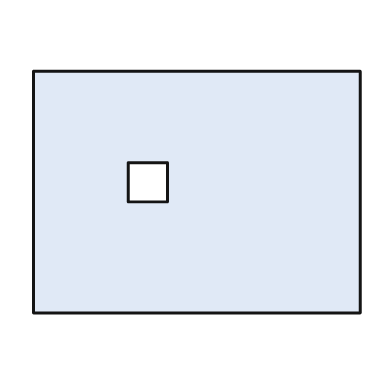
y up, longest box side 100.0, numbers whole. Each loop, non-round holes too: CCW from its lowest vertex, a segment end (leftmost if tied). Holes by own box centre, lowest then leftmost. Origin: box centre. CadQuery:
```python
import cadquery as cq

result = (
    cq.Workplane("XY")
    .moveTo(-50.0, -37.0)
    .lineTo(50.0, -37.0)
    .lineTo(50.0, 37.0)
    .lineTo(-50.0, 37.0)
    .close()
    .moveTo(-21.0, -3.0)
    .lineTo(-9.0, -3.0)
    .lineTo(-9.0, 9.0)
    .lineTo(-21.0, 9.0)
    .close()
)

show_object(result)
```